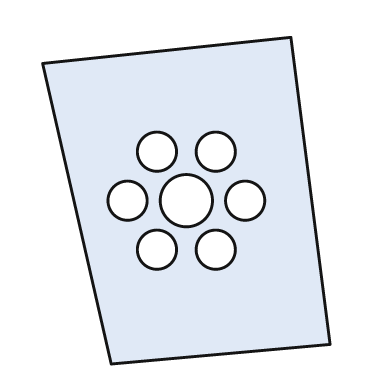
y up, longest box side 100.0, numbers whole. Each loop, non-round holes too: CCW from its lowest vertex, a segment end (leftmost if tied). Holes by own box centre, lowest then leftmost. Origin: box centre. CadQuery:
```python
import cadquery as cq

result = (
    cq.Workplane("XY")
    .moveTo(-23.0, -50.0)
    .lineTo(44.0, -44.0)
    .lineTo(32.0, 50.0)
    .lineTo(-44.0, 42.0)
    .close()
    .moveTo(-9.0, -15.0)
    .circle(6.0)
    .moveTo(9.0, -15.0)
    .circle(6.0)
    .moveTo(-18.0, 0.0)
    .circle(6.0)
    .moveTo(0.0, 0.0)
    .circle(8.0)
    .moveTo(18.0, 0.0)
    .circle(6.0)
    .moveTo(-9.0, 15.0)
    .circle(6.0)
    .moveTo(9.0, 15.0)
    .circle(6.0)
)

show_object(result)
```